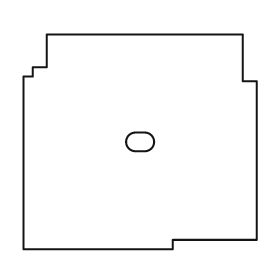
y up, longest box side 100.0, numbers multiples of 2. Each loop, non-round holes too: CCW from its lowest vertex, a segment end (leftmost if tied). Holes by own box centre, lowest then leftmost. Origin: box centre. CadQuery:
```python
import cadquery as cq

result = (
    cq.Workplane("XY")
    .moveTo(-50.0, -46.0)
    .lineTo(14.0, -46.0)
    .lineTo(14.0, -42.0)
    .lineTo(50.0, -42.0)
    .lineTo(50.0, 26.0)
    .lineTo(44.0, 26.0)
    .lineTo(44.0, 46.0)
    .lineTo(-40.0, 46.0)
    .lineTo(-40.0, 32.0)
    .lineTo(-46.0, 32.0)
    .lineTo(-46.0, 28.0)
    .lineTo(-50.0, 28.0)
    .close()
    .moveTo(-2.0, -4.0)
    .lineTo(2.0, -4.0)
    .threePointArc((6.0, 0.0), (2.0, 4.0))
    .lineTo(-2.0, 4.0)
    .threePointArc((-6.0, 0.0), (-2.0, -4.0))
    .close()
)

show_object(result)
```